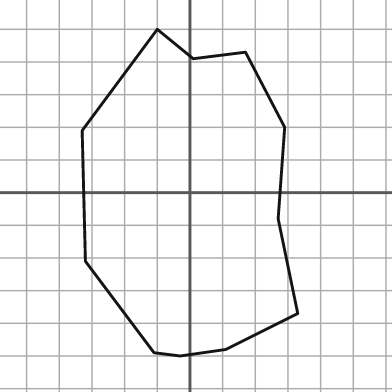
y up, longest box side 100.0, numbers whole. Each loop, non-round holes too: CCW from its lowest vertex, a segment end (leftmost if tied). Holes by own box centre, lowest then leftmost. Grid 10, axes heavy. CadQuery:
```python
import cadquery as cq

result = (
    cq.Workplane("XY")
    .moveTo(-3.0, -50.0)
    .lineTo(11.0, -48.0)
    .lineTo(33.0, -37.0)
    .lineTo(27.0, -8.0)
    .lineTo(29.0, 20.0)
    .lineTo(17.0, 43.0)
    .lineTo(1.0, 41.0)
    .lineTo(-10.0, 50.0)
    .lineTo(-33.0, 19.0)
    .lineTo(-32.0, -21.0)
    .lineTo(-11.0, -49.0)
    .close()
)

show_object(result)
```